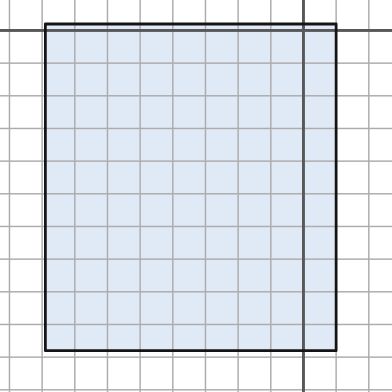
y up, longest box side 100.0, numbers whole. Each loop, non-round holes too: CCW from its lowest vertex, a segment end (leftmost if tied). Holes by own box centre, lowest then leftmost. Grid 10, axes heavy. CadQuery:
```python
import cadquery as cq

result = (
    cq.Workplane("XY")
    .moveTo(-79.0, -98.0)
    .lineTo(10.0, -98.0)
    .lineTo(10.0, 2.0)
    .lineTo(-79.0, 2.0)
    .close()
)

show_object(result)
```